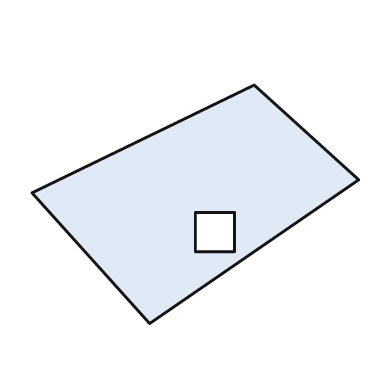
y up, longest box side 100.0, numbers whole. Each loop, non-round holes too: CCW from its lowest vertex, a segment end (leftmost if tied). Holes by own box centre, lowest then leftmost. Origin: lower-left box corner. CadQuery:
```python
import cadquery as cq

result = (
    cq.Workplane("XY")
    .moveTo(36.0, 0.0)
    .lineTo(100.0, 44.0)
    .lineTo(68.0, 73.0)
    .lineTo(0.0, 40.0)
    .close()
    .moveTo(50.0, 22.0)
    .lineTo(62.0, 22.0)
    .lineTo(62.0, 34.0)
    .lineTo(50.0, 34.0)
    .close()
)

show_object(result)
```